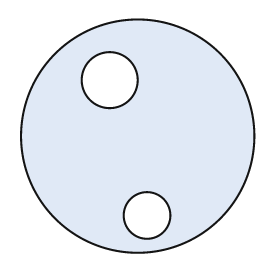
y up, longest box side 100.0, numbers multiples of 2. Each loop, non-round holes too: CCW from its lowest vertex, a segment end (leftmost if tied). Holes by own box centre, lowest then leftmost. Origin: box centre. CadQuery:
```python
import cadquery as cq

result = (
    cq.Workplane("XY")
    .moveTo(0.0, 0.0)
    .circle(50.0)
    .moveTo(4.0, -34.0)
    .circle(10.0)
    .moveTo(-12.0, 24.0)
    .circle(12.0)
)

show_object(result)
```